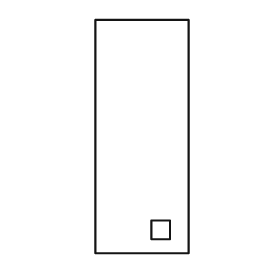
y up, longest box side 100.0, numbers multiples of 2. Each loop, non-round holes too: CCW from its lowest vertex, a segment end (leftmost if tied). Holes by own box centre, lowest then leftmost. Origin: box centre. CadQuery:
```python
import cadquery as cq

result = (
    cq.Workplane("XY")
    .moveTo(-20.0, -50.0)
    .lineTo(20.0, -50.0)
    .lineTo(20.0, 50.0)
    .lineTo(-20.0, 50.0)
    .close()
    .moveTo(4.0, -44.0)
    .lineTo(12.0, -44.0)
    .lineTo(12.0, -36.0)
    .lineTo(4.0, -36.0)
    .close()
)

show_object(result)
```